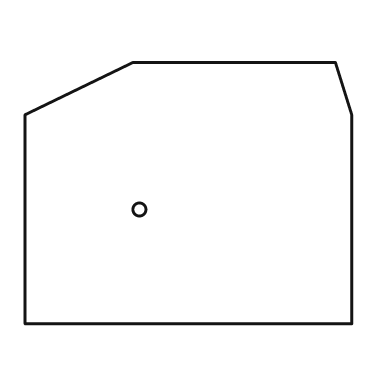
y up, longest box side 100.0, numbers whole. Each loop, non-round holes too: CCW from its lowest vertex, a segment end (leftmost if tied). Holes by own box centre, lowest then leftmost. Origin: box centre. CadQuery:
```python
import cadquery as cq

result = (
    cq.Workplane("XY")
    .moveTo(-50.0, -40.0)
    .lineTo(50.0, -40.0)
    .lineTo(50.0, 24.0)
    .lineTo(45.0, 40.0)
    .lineTo(-17.0, 40.0)
    .lineTo(-50.0, 24.0)
    .close()
    .moveTo(-15.0, -5.0)
    .circle(2.0)
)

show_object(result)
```